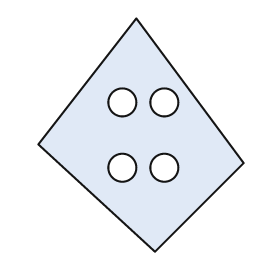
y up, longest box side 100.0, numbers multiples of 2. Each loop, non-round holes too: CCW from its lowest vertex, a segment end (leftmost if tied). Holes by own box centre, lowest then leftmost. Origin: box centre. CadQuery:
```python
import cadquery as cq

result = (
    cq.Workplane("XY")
    .moveTo(6.0, -50.0)
    .lineTo(44.0, -12.0)
    .lineTo(-2.0, 50.0)
    .lineTo(-44.0, -4.0)
    .close()
    .moveTo(-8.0, -14.0)
    .circle(6.0)
    .moveTo(10.0, -14.0)
    .circle(6.0)
    .moveTo(-8.0, 14.0)
    .circle(6.0)
    .moveTo(10.0, 14.0)
    .circle(6.0)
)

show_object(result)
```